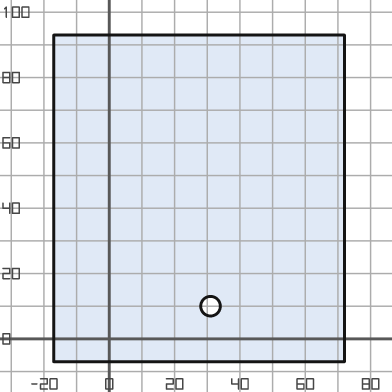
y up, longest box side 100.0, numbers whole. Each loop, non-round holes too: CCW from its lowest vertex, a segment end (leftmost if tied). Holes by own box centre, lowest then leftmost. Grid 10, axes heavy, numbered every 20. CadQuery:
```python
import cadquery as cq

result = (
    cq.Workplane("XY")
    .moveTo(-17.0, -7.0)
    .lineTo(72.0, -7.0)
    .lineTo(72.0, 93.0)
    .lineTo(-17.0, 93.0)
    .close()
    .moveTo(31.0, 10.0)
    .circle(3.0)
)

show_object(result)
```